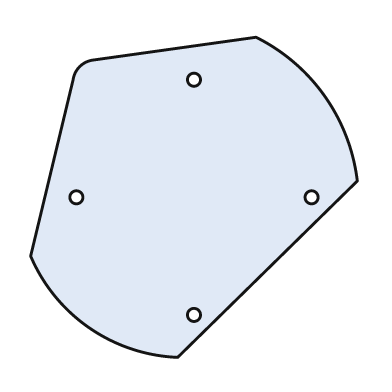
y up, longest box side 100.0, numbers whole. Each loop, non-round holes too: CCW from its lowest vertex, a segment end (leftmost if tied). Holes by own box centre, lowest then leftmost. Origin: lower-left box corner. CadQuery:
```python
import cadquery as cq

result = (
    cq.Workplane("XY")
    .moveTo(45.0, 0.0)
    .lineTo(100.0, 54.0)
    .threePointArc((90.0, 80.0), (69.0, 98.0))
    .lineTo(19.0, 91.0)
    .threePointArc((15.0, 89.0), (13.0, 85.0))
    .lineTo(0.0, 31.0)
    .threePointArc((18.0, 9.0), (45.0, 0.0))
    .close()
    .moveTo(50.0, 13.0)
    .circle(2.0)
    .moveTo(14.0, 49.0)
    .circle(2.0)
    .moveTo(86.0, 49.0)
    .circle(2.0)
    .moveTo(50.0, 85.0)
    .circle(2.0)
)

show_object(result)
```